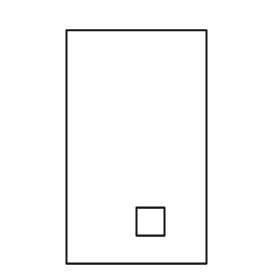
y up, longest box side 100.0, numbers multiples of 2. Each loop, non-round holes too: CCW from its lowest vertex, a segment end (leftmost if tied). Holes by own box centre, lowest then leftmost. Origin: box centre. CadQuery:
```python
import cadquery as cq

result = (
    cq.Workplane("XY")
    .moveTo(-30.0, -50.0)
    .lineTo(30.0, -50.0)
    .lineTo(30.0, 50.0)
    .lineTo(-30.0, 50.0)
    .close()
    .moveTo(0.0, -38.0)
    .lineTo(12.0, -38.0)
    .lineTo(12.0, -26.0)
    .lineTo(0.0, -26.0)
    .close()
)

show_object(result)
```